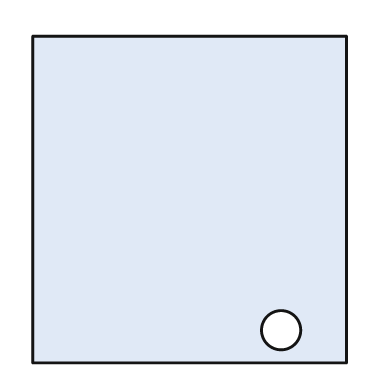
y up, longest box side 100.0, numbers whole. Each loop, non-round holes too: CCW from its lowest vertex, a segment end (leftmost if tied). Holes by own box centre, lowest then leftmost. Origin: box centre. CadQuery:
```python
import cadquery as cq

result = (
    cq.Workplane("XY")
    .moveTo(-48.0, -50.0)
    .lineTo(48.0, -50.0)
    .lineTo(48.0, 50.0)
    .lineTo(-48.0, 50.0)
    .close()
    .moveTo(28.0, -40.0)
    .circle(6.0)
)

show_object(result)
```